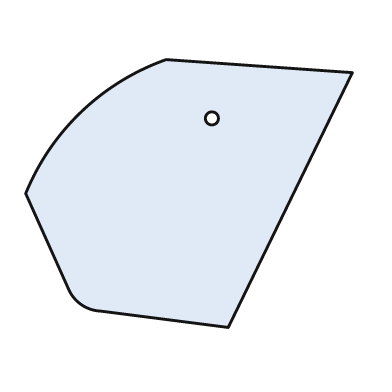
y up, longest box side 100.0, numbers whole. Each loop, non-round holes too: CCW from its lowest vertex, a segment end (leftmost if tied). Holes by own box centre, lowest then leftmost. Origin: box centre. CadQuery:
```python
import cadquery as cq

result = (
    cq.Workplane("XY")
    .moveTo(12.0, -41.0)
    .lineTo(50.0, 37.0)
    .lineTo(-7.0, 41.0)
    .threePointArc((-33.0, 25.0), (-50.0, 0.0))
    .lineTo(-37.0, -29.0)
    .threePointArc((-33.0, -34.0), (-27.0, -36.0))
    .close()
    .moveTo(7.0, 23.0)
    .circle(2.0)
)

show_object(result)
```